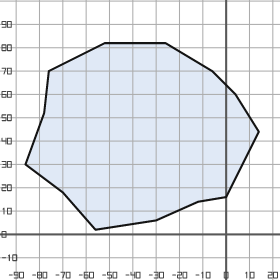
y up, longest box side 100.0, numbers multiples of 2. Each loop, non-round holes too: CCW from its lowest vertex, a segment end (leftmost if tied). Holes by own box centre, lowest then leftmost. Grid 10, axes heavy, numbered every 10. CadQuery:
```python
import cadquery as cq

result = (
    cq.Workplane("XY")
    .moveTo(-56.0, 2.0)
    .lineTo(-30.0, 6.0)
    .lineTo(-12.0, 14.0)
    .lineTo(0.0, 16.0)
    .lineTo(14.0, 44.0)
    .lineTo(4.0, 60.0)
    .lineTo(-6.0, 70.0)
    .lineTo(-26.0, 82.0)
    .lineTo(-52.0, 82.0)
    .lineTo(-76.0, 70.0)
    .lineTo(-78.0, 52.0)
    .lineTo(-86.0, 30.0)
    .lineTo(-70.0, 18.0)
    .close()
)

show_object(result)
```